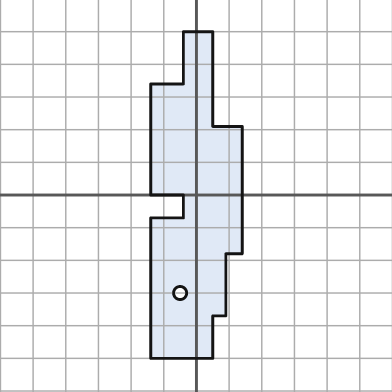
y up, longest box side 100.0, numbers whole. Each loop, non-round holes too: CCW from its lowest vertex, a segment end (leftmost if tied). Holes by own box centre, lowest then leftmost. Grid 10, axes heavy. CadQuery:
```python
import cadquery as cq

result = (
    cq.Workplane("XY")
    .moveTo(-14.0, -50.0)
    .lineTo(5.0, -50.0)
    .lineTo(5.0, -37.0)
    .lineTo(9.0, -37.0)
    .lineTo(9.0, -18.0)
    .lineTo(14.0, -18.0)
    .lineTo(14.0, 21.0)
    .lineTo(5.0, 21.0)
    .lineTo(5.0, 50.0)
    .lineTo(-4.0, 50.0)
    .lineTo(-4.0, 34.0)
    .lineTo(-14.0, 34.0)
    .lineTo(-14.0, 0.0)
    .lineTo(-4.0, 0.0)
    .lineTo(-4.0, -7.0)
    .lineTo(-14.0, -7.0)
    .close()
    .moveTo(-5.0, -30.0)
    .circle(2.0)
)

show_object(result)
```